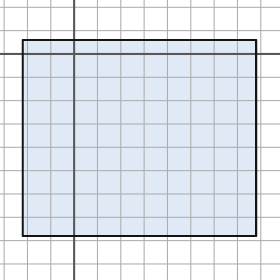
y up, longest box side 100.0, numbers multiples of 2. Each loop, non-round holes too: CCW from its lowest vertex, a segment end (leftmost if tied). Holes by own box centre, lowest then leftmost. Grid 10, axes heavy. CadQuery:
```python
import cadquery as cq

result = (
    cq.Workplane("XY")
    .moveTo(-22.0, -78.0)
    .lineTo(78.0, -78.0)
    .lineTo(78.0, 6.0)
    .lineTo(-22.0, 6.0)
    .close()
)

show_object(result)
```